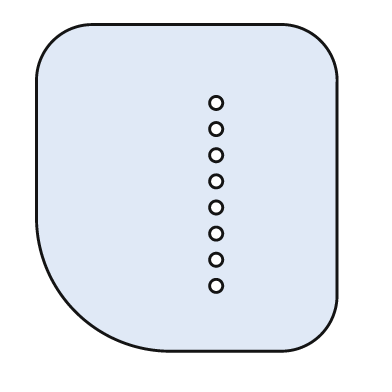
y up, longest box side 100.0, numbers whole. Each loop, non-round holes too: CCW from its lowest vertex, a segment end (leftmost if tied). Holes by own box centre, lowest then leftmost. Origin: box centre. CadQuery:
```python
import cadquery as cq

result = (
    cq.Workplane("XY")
    .moveTo(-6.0, -50.0)
    .lineTo(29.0, -50.0)
    .threePointArc((41.0, -45.0), (46.0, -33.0))
    .lineTo(46.0, 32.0)
    .threePointArc((41.0, 45.0), (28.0, 50.0))
    .lineTo(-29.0, 50.0)
    .threePointArc((-41.0, 45.0), (-46.0, 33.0))
    .lineTo(-46.0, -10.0)
    .threePointArc((-34.0, -38.0), (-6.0, -50.0))
    .close()
    .moveTo(9.0, -30.0)
    .circle(2.0)
    .moveTo(9.0, -22.0)
    .circle(2.0)
    .moveTo(9.0, -14.0)
    .circle(2.0)
    .moveTo(9.0, -6.0)
    .circle(2.0)
    .moveTo(9.0, 2.0)
    .circle(2.0)
    .moveTo(9.0, 10.0)
    .circle(2.0)
    .moveTo(9.0, 18.0)
    .circle(2.0)
    .moveTo(9.0, 26.0)
    .circle(2.0)
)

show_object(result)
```